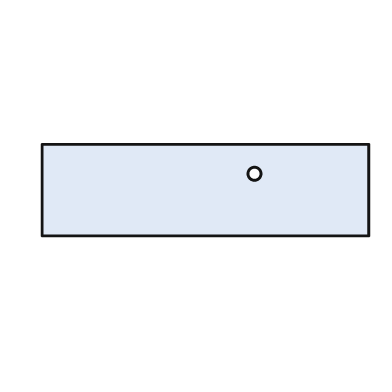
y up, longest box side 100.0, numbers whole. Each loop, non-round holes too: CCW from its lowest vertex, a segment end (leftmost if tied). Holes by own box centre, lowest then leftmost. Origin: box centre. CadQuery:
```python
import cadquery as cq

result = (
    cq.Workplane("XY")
    .moveTo(-50.0, -14.0)
    .lineTo(50.0, -14.0)
    .lineTo(50.0, 14.0)
    .lineTo(-50.0, 14.0)
    .close()
    .moveTo(15.0, 5.0)
    .circle(2.0)
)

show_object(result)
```